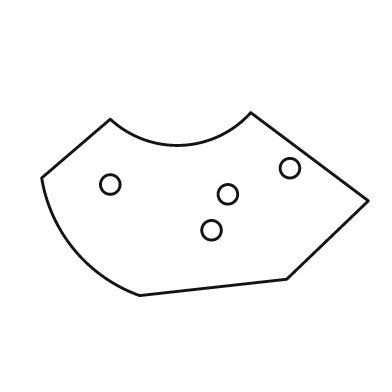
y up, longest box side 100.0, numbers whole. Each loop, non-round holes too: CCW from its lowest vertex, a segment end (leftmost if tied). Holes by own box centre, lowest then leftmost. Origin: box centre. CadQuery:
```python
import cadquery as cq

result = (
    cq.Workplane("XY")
    .moveTo(-20.0, -28.0)
    .lineTo(25.0, -23.0)
    .lineTo(50.0, 1.0)
    .lineTo(14.0, 28.0)
    .threePointArc((-7.0, 18.0), (-29.0, 26.0))
    .lineTo(-50.0, 8.0)
    .threePointArc((-40.0, -14.0), (-20.0, -28.0))
    .close()
    .moveTo(2.0, -8.0)
    .circle(3.0)
    .moveTo(7.0, 3.0)
    .circle(3.0)
    .moveTo(-29.0, 6.0)
    .circle(3.0)
    .moveTo(26.0, 11.0)
    .circle(3.0)
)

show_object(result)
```